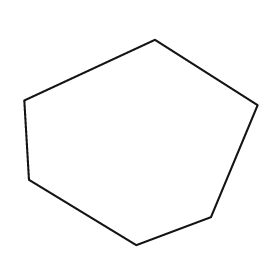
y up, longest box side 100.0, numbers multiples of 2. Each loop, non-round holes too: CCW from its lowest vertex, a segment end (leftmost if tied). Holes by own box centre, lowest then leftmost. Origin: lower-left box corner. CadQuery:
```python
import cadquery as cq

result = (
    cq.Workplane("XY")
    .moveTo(48.0, 0.0)
    .lineTo(80.0, 12.0)
    .lineTo(100.0, 60.0)
    .lineTo(56.0, 88.0)
    .lineTo(0.0, 62.0)
    .lineTo(2.0, 28.0)
    .close()
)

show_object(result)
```